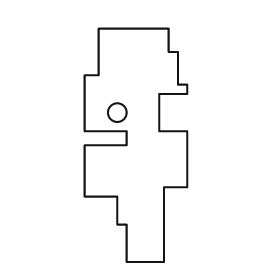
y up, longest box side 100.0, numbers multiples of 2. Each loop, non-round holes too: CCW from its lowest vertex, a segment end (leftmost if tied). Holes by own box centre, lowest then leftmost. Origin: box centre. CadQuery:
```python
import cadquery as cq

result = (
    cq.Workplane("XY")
    .moveTo(-4.0, -50.0)
    .lineTo(12.0, -50.0)
    .lineTo(12.0, -18.0)
    .lineTo(22.0, -18.0)
    .lineTo(22.0, 6.0)
    .lineTo(10.0, 6.0)
    .lineTo(10.0, 22.0)
    .lineTo(22.0, 22.0)
    .lineTo(22.0, 26.0)
    .lineTo(18.0, 26.0)
    .lineTo(18.0, 40.0)
    .lineTo(14.0, 40.0)
    .lineTo(14.0, 50.0)
    .lineTo(-16.0, 50.0)
    .lineTo(-16.0, 30.0)
    .lineTo(-22.0, 30.0)
    .lineTo(-22.0, 6.0)
    .lineTo(-4.0, 6.0)
    .lineTo(-4.0, 0.0)
    .lineTo(-22.0, 0.0)
    .lineTo(-22.0, -22.0)
    .lineTo(-8.0, -22.0)
    .lineTo(-8.0, -34.0)
    .lineTo(-4.0, -34.0)
    .close()
    .moveTo(-8.0, 14.0)
    .circle(4.0)
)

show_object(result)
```